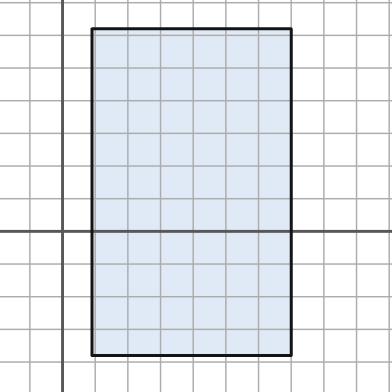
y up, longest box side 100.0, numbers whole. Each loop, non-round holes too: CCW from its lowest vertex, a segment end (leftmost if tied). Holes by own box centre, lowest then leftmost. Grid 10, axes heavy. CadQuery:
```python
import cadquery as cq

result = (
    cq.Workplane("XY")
    .moveTo(9.0, -38.0)
    .lineTo(70.0, -38.0)
    .lineTo(70.0, 62.0)
    .lineTo(9.0, 62.0)
    .close()
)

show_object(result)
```